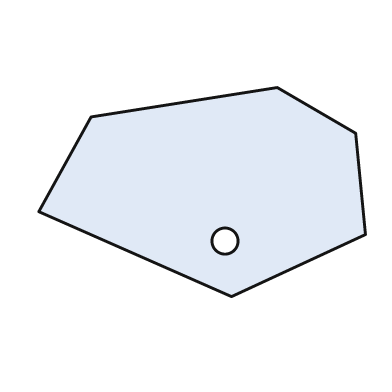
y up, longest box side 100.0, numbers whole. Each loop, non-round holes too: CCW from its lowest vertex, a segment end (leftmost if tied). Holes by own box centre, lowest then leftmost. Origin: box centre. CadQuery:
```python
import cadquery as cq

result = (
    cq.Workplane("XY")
    .moveTo(9.0, -32.0)
    .lineTo(50.0, -13.0)
    .lineTo(47.0, 18.0)
    .lineTo(23.0, 32.0)
    .lineTo(-34.0, 23.0)
    .lineTo(-50.0, -6.0)
    .close()
    .moveTo(7.0, -15.0)
    .circle(4.0)
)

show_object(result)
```